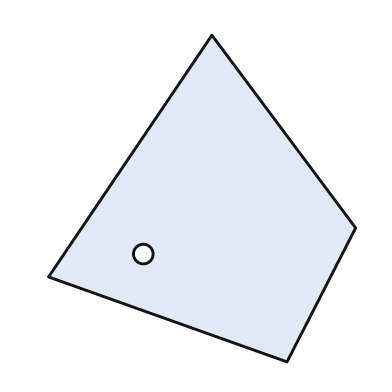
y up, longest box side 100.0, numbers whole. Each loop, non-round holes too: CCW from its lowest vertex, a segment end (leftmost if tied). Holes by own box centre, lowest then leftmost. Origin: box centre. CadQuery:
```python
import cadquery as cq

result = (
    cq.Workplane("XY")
    .moveTo(26.0, -50.0)
    .lineTo(47.0, -9.0)
    .lineTo(3.0, 50.0)
    .lineTo(-47.0, -24.0)
    .close()
    .moveTo(-18.0, -17.0)
    .circle(3.0)
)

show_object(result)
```